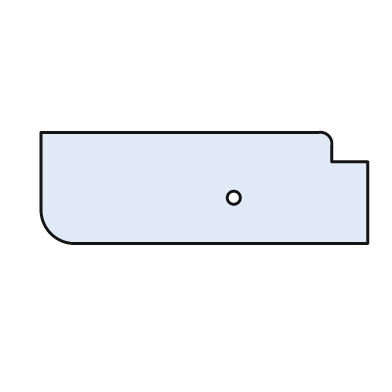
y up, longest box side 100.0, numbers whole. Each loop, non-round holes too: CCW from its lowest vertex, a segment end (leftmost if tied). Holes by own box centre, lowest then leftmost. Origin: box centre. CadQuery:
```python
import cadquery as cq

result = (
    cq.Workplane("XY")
    .moveTo(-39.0, -17.0)
    .lineTo(50.0, -17.0)
    .lineTo(50.0, 8.0)
    .lineTo(39.0, 8.0)
    .lineTo(39.0, 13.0)
    .threePointArc((38.0, 16.0), (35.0, 17.0))
    .lineTo(-50.0, 17.0)
    .lineTo(-50.0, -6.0)
    .threePointArc((-47.0, -14.0), (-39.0, -17.0))
    .close()
    .moveTo(9.0, -3.0)
    .circle(2.0)
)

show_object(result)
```